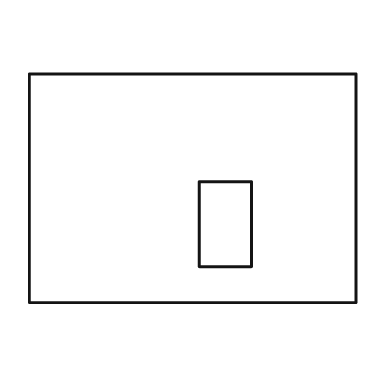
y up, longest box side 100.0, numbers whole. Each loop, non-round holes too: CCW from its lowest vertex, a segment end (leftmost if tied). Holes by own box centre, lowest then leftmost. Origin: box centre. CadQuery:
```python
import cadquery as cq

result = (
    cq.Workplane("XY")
    .moveTo(-50.0, -35.0)
    .lineTo(50.0, -35.0)
    .lineTo(50.0, 35.0)
    .lineTo(-50.0, 35.0)
    .close()
    .moveTo(2.0, -24.0)
    .lineTo(18.0, -24.0)
    .lineTo(18.0, 2.0)
    .lineTo(2.0, 2.0)
    .close()
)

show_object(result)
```